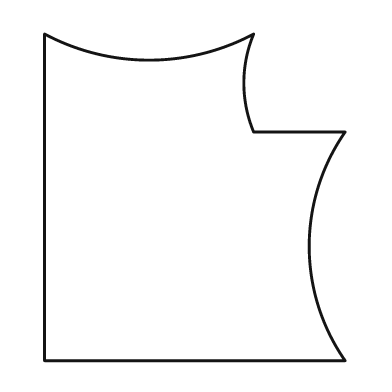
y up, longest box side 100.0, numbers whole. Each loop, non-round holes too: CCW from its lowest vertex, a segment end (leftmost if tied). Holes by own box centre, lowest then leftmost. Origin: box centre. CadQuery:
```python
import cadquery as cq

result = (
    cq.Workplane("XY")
    .moveTo(-46.0, -50.0)
    .lineTo(46.0, -50.0)
    .threePointArc((35.0, -15.0), (46.0, 20.0))
    .lineTo(18.0, 20.0)
    .threePointArc((15.0, 35.0), (18.0, 50.0))
    .threePointArc((-14.0, 42.0), (-46.0, 50.0))
    .close()
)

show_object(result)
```